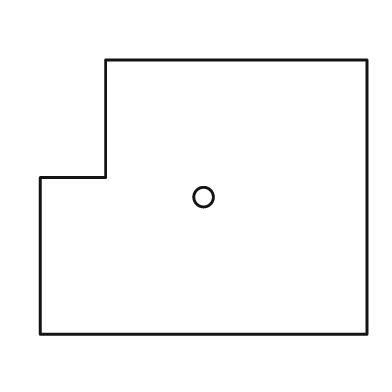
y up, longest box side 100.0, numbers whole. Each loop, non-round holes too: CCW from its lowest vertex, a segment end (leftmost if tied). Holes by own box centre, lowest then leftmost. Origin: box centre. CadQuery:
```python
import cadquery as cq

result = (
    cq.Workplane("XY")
    .moveTo(-50.0, -42.0)
    .lineTo(50.0, -42.0)
    .lineTo(50.0, 42.0)
    .lineTo(-30.0, 42.0)
    .lineTo(-30.0, 6.0)
    .lineTo(-50.0, 6.0)
    .close()
    .moveTo(0.0, 0.0)
    .circle(3.0)
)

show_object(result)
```